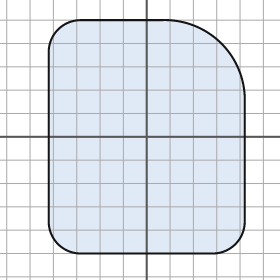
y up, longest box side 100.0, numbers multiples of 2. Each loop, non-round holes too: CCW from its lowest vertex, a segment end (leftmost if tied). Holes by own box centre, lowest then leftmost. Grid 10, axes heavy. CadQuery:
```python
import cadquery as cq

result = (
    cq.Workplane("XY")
    .moveTo(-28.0, -50.0)
    .lineTo(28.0, -50.0)
    .threePointArc((38.0, -46.0), (42.0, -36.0))
    .lineTo(42.0, 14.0)
    .threePointArc((32.0, 40.0), (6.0, 50.0))
    .lineTo(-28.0, 50.0)
    .threePointArc((-38.0, 46.0), (-42.0, 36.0))
    .lineTo(-42.0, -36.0)
    .threePointArc((-38.0, -46.0), (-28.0, -50.0))
    .close()
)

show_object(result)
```